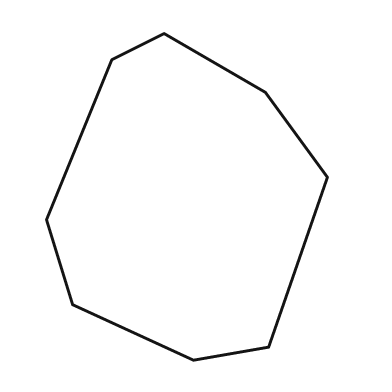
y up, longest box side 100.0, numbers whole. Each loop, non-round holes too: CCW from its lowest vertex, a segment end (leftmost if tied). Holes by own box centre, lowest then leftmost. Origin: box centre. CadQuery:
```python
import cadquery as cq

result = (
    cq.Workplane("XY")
    .moveTo(2.0, -50.0)
    .lineTo(25.0, -46.0)
    .lineTo(43.0, 6.0)
    .lineTo(24.0, 32.0)
    .lineTo(-7.0, 50.0)
    .lineTo(-23.0, 42.0)
    .lineTo(-43.0, -7.0)
    .lineTo(-35.0, -33.0)
    .close()
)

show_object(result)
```